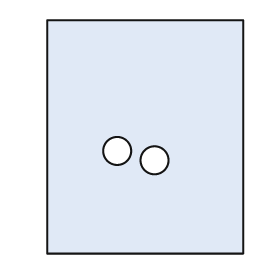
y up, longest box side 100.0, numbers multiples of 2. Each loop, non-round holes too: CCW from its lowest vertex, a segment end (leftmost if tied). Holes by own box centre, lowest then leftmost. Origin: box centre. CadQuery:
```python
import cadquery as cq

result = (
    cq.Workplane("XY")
    .moveTo(-42.0, -50.0)
    .lineTo(42.0, -50.0)
    .lineTo(42.0, 50.0)
    .lineTo(-42.0, 50.0)
    .close()
    .moveTo(4.0, -10.0)
    .circle(6.0)
    .moveTo(-12.0, -6.0)
    .circle(6.0)
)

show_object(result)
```